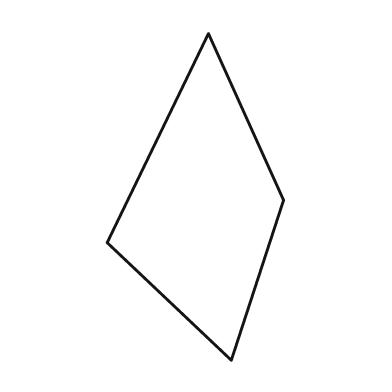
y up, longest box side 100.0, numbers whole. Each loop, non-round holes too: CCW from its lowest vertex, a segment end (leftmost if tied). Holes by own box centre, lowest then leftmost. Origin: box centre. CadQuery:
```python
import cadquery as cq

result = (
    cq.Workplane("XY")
    .moveTo(11.0, -50.0)
    .lineTo(27.0, -1.0)
    .lineTo(4.0, 50.0)
    .lineTo(-27.0, -14.0)
    .close()
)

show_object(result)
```